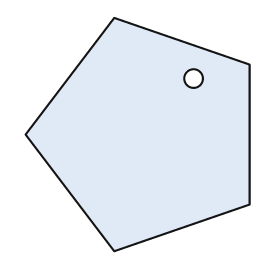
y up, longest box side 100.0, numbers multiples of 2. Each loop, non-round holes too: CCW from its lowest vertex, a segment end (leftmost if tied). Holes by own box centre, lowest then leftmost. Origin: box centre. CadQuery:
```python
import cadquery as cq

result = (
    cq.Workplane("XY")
    .moveTo(-10.0, -50.0)
    .lineTo(48.0, -30.0)
    .lineTo(48.0, 30.0)
    .lineTo(-10.0, 50.0)
    .lineTo(-48.0, 0.0)
    .close()
    .moveTo(24.0, 24.0)
    .circle(4.0)
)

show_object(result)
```